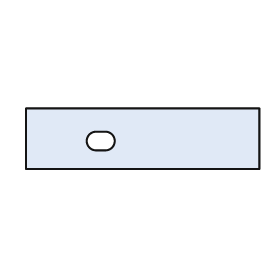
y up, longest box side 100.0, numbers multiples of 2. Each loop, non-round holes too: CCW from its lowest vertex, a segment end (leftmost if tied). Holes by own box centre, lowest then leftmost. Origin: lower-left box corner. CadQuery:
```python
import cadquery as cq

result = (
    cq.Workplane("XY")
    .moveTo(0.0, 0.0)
    .lineTo(100.0, 0.0)
    .lineTo(100.0, 26.0)
    .lineTo(0.0, 26.0)
    .close()
    .moveTo(30.0, 8.0)
    .lineTo(34.0, 8.0)
    .threePointArc((38.0, 12.0), (34.0, 16.0))
    .lineTo(30.0, 16.0)
    .threePointArc((26.0, 12.0), (30.0, 8.0))
    .close()
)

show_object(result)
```